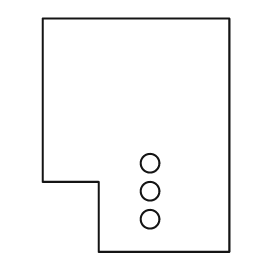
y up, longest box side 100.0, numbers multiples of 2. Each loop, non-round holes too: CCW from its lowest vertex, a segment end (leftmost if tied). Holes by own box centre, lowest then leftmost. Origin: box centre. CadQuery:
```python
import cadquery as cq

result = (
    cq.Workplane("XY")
    .moveTo(-16.0, -50.0)
    .lineTo(40.0, -50.0)
    .lineTo(40.0, 50.0)
    .lineTo(-40.0, 50.0)
    .lineTo(-40.0, -20.0)
    .lineTo(-16.0, -20.0)
    .close()
    .moveTo(6.0, -36.0)
    .circle(4.0)
    .moveTo(6.0, -24.0)
    .circle(4.0)
    .moveTo(6.0, -12.0)
    .circle(4.0)
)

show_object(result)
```